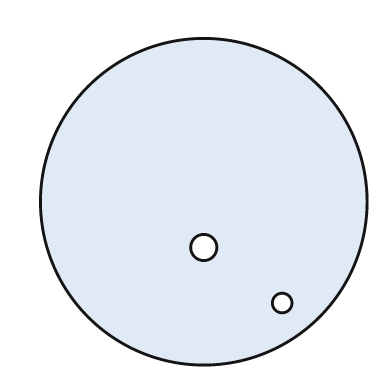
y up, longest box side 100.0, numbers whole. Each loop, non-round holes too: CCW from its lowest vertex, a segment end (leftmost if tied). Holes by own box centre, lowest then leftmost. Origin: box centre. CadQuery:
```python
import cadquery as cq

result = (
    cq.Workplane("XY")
    .moveTo(0.0, 0.0)
    .circle(50.0)
    .moveTo(24.0, -31.0)
    .circle(3.0)
    .moveTo(0.0, -14.0)
    .circle(4.0)
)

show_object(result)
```